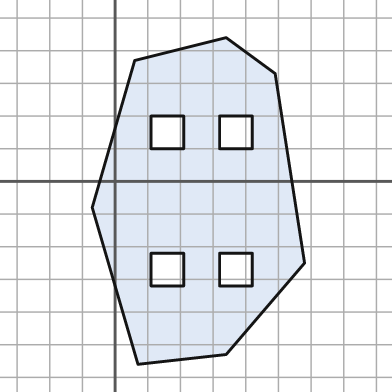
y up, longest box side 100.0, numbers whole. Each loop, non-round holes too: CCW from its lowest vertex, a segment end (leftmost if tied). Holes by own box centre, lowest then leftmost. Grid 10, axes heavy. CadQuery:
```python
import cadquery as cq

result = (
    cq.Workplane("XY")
    .moveTo(7.0, -56.0)
    .lineTo(34.0, -53.0)
    .lineTo(58.0, -25.0)
    .lineTo(49.0, 33.0)
    .lineTo(34.0, 44.0)
    .lineTo(6.0, 37.0)
    .lineTo(-7.0, -8.0)
    .close()
    .moveTo(11.0, -32.0)
    .lineTo(21.0, -32.0)
    .lineTo(21.0, -22.0)
    .lineTo(11.0, -22.0)
    .close()
    .moveTo(32.0, -32.0)
    .lineTo(42.0, -32.0)
    .lineTo(42.0, -22.0)
    .lineTo(32.0, -22.0)
    .close()
    .moveTo(11.0, 10.0)
    .lineTo(21.0, 10.0)
    .lineTo(21.0, 20.0)
    .lineTo(11.0, 20.0)
    .close()
    .moveTo(32.0, 10.0)
    .lineTo(42.0, 10.0)
    .lineTo(42.0, 20.0)
    .lineTo(32.0, 20.0)
    .close()
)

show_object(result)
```